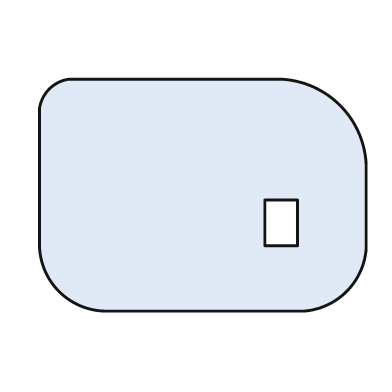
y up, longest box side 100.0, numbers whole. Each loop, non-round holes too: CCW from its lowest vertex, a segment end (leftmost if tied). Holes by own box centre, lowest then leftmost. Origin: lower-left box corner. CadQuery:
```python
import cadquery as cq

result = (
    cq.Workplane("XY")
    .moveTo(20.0, 0.0)
    .lineTo(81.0, 0.0)
    .threePointArc((94.0, 6.0), (100.0, 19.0))
    .lineTo(100.0, 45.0)
    .threePointArc((92.0, 63.0), (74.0, 71.0))
    .lineTo(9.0, 71.0)
    .threePointArc((3.0, 68.0), (0.0, 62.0))
    .lineTo(0.0, 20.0)
    .threePointArc((6.0, 6.0), (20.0, 0.0))
    .close()
    .moveTo(69.0, 20.0)
    .lineTo(79.0, 20.0)
    .lineTo(79.0, 34.0)
    .lineTo(69.0, 34.0)
    .close()
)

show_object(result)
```